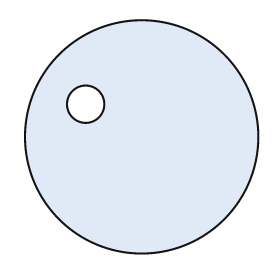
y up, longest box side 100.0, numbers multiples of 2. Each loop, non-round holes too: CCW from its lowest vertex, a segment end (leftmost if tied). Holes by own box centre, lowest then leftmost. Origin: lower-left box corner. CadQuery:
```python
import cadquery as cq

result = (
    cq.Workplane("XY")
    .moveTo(50.0, 50.0)
    .circle(50.0)
    .moveTo(26.0, 64.0)
    .circle(8.0)
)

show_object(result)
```